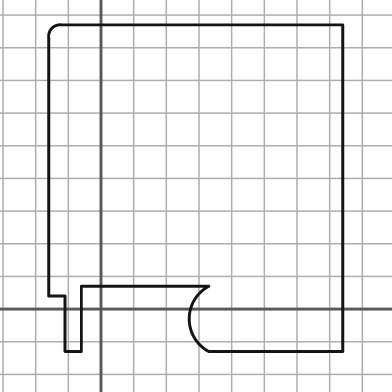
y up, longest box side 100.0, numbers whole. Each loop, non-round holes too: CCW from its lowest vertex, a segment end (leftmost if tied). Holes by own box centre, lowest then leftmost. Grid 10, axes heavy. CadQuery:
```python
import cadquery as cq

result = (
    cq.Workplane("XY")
    .moveTo(-11.0, -13.0)
    .lineTo(-6.0, -13.0)
    .lineTo(-6.0, 7.0)
    .lineTo(33.0, 7.0)
    .threePointArc((27.0, -3.0), (33.0, -13.0))
    .lineTo(74.0, -13.0)
    .lineTo(74.0, 87.0)
    .lineTo(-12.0, 87.0)
    .threePointArc((-15.0, 86.0), (-16.0, 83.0))
    .lineTo(-16.0, 4.0)
    .lineTo(-11.0, 4.0)
    .close()
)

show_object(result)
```